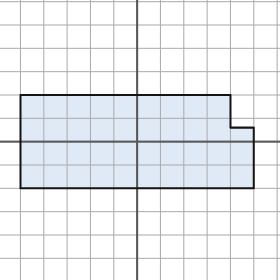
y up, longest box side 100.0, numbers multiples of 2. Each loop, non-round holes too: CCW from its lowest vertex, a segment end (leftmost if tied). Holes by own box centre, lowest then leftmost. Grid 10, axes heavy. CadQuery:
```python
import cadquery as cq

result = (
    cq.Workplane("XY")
    .moveTo(-50.0, -20.0)
    .lineTo(50.0, -20.0)
    .lineTo(50.0, 6.0)
    .lineTo(40.0, 6.0)
    .lineTo(40.0, 20.0)
    .lineTo(-50.0, 20.0)
    .close()
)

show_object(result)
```